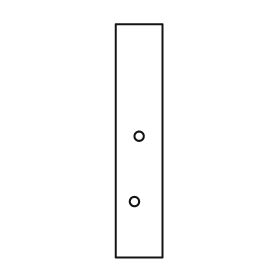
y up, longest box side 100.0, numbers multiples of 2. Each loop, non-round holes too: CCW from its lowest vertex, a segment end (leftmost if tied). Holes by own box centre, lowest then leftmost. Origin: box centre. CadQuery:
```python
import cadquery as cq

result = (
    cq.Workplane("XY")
    .moveTo(-10.0, -50.0)
    .lineTo(10.0, -50.0)
    .lineTo(10.0, 50.0)
    .lineTo(-10.0, 50.0)
    .close()
    .moveTo(-2.0, -26.0)
    .circle(2.0)
    .moveTo(0.0, 2.0)
    .circle(2.0)
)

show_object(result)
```